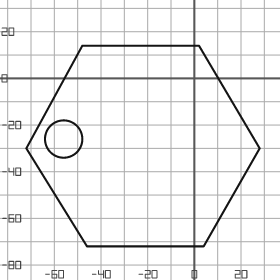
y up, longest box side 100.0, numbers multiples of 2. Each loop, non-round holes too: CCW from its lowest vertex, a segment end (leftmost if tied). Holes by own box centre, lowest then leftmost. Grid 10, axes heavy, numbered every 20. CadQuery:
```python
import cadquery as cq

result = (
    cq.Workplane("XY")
    .moveTo(-46.0, -72.0)
    .lineTo(4.0, -72.0)
    .lineTo(28.0, -30.0)
    .lineTo(2.0, 14.0)
    .lineTo(-48.0, 14.0)
    .lineTo(-72.0, -30.0)
    .close()
    .moveTo(-56.0, -26.0)
    .circle(8.0)
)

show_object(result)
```